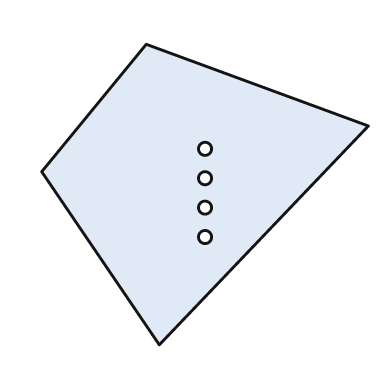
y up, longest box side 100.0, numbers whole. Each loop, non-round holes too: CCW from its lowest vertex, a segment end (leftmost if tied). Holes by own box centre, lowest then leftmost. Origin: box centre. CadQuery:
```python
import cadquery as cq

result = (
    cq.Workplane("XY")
    .moveTo(-14.0, -46.0)
    .lineTo(50.0, 21.0)
    .lineTo(-18.0, 46.0)
    .lineTo(-50.0, 7.0)
    .close()
    .moveTo(0.0, -13.0)
    .circle(2.0)
    .moveTo(0.0, -4.0)
    .circle(2.0)
    .moveTo(0.0, 5.0)
    .circle(2.0)
    .moveTo(0.0, 14.0)
    .circle(2.0)
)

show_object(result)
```